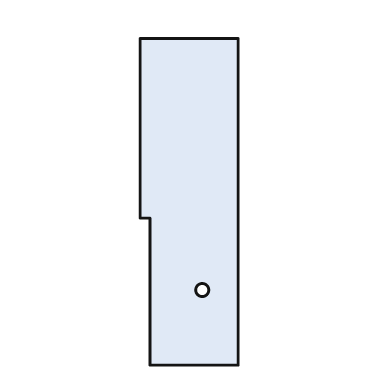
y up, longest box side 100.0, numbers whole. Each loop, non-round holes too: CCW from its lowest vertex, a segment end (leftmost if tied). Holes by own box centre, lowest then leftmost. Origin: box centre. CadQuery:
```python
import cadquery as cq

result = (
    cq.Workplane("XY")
    .moveTo(-12.0, -50.0)
    .lineTo(15.0, -50.0)
    .lineTo(15.0, 50.0)
    .lineTo(-15.0, 50.0)
    .lineTo(-15.0, -5.0)
    .lineTo(-12.0, -5.0)
    .close()
    .moveTo(4.0, -27.0)
    .circle(2.0)
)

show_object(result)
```